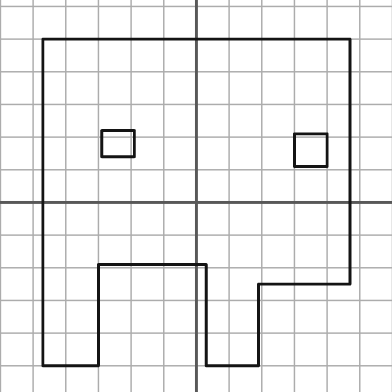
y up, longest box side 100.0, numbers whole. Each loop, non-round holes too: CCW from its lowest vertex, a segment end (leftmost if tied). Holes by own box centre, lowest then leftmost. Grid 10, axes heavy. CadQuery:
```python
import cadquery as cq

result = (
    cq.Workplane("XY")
    .moveTo(-47.0, -50.0)
    .lineTo(-30.0, -50.0)
    .lineTo(-30.0, -19.0)
    .lineTo(3.0, -19.0)
    .lineTo(3.0, -50.0)
    .lineTo(19.0, -50.0)
    .lineTo(19.0, -25.0)
    .lineTo(47.0, -25.0)
    .lineTo(47.0, 50.0)
    .lineTo(-47.0, 50.0)
    .close()
    .moveTo(30.0, 11.0)
    .lineTo(40.0, 11.0)
    .lineTo(40.0, 21.0)
    .lineTo(30.0, 21.0)
    .close()
    .moveTo(-29.0, 14.0)
    .lineTo(-19.0, 14.0)
    .lineTo(-19.0, 22.0)
    .lineTo(-29.0, 22.0)
    .close()
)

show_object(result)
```